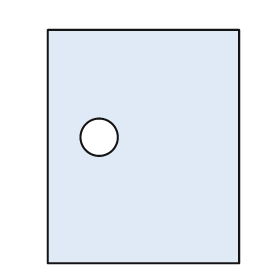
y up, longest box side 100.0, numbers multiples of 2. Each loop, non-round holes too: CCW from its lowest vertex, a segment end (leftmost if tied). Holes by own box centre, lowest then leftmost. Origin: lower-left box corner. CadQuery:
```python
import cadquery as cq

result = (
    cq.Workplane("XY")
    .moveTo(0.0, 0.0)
    .lineTo(82.0, 0.0)
    .lineTo(82.0, 100.0)
    .lineTo(0.0, 100.0)
    .close()
    .moveTo(22.0, 54.0)
    .circle(8.0)
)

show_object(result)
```